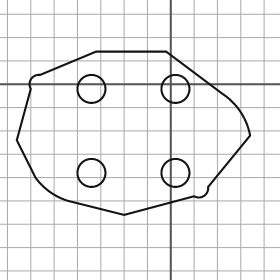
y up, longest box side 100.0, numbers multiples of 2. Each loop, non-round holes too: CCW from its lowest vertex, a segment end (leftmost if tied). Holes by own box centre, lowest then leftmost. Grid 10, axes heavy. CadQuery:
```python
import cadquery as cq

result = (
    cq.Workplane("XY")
    .moveTo(-20.0, -56.0)
    .lineTo(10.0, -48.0)
    .threePointArc((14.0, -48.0), (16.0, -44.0))
    .lineTo(34.0, -22.0)
    .threePointArc((30.0, -12.0), (22.0, -4.0))
    .lineTo(-2.0, 14.0)
    .lineTo(-32.0, 14.0)
    .lineTo(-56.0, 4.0)
    .threePointArc((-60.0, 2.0), (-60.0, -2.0))
    .lineTo(-66.0, -24.0)
    .lineTo(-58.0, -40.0)
    .threePointArc((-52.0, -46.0), (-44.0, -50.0))
    .close()
    .moveTo(-34.0, -38.0)
    .circle(6.0)
    .moveTo(2.0, -38.0)
    .circle(6.0)
    .moveTo(-34.0, -2.0)
    .circle(6.0)
    .moveTo(2.0, -2.0)
    .circle(6.0)
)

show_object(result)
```